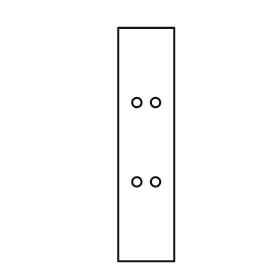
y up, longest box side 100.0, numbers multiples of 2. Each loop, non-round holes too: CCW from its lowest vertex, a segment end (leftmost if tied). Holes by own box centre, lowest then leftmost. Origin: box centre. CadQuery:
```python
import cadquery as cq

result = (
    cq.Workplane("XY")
    .moveTo(-12.0, -50.0)
    .lineTo(12.0, -50.0)
    .lineTo(12.0, 50.0)
    .lineTo(-12.0, 50.0)
    .close()
    .moveTo(-4.0, -16.0)
    .circle(2.0)
    .moveTo(4.0, -16.0)
    .circle(2.0)
    .moveTo(-4.0, 18.0)
    .circle(2.0)
    .moveTo(4.0, 18.0)
    .circle(2.0)
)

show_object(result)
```